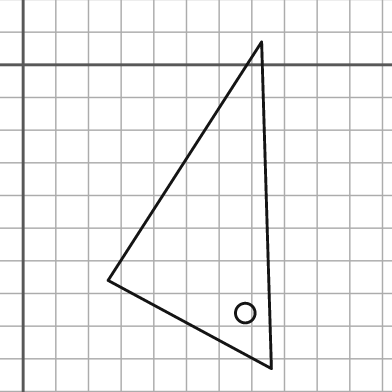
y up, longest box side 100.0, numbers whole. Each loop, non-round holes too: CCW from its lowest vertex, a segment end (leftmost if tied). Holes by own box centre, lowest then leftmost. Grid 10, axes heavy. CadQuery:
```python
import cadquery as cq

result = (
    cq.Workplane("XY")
    .moveTo(76.0, -93.0)
    .lineTo(73.0, 7.0)
    .lineTo(26.0, -66.0)
    .close()
    .moveTo(68.0, -76.0)
    .circle(3.0)
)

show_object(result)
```